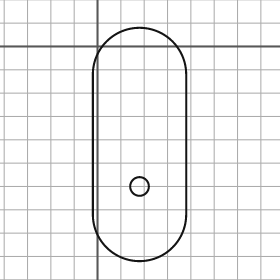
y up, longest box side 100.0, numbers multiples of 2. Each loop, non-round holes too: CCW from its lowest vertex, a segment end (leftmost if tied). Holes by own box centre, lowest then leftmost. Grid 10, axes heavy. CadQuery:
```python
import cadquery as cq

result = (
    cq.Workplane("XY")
    .moveTo(-2.0, -72.0)
    .threePointArc((18.0, -92.0), (38.0, -72.0))
    .lineTo(38.0, -12.0)
    .threePointArc((18.0, 8.0), (-2.0, -12.0))
    .close()
    .moveTo(18.0, -60.0)
    .circle(4.0)
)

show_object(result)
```